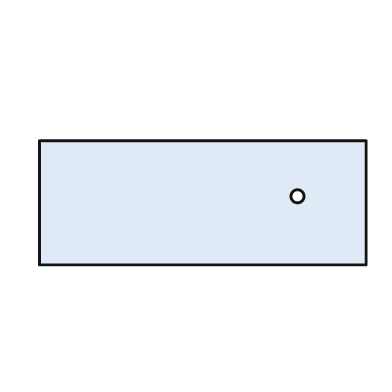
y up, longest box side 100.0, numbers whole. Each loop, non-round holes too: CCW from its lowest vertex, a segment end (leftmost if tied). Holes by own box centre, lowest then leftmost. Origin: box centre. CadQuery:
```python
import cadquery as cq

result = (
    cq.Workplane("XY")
    .moveTo(-50.0, -19.0)
    .lineTo(50.0, -19.0)
    .lineTo(50.0, 19.0)
    .lineTo(-50.0, 19.0)
    .close()
    .moveTo(29.0, 2.0)
    .circle(2.0)
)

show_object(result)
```